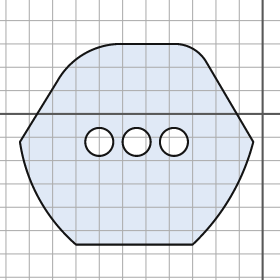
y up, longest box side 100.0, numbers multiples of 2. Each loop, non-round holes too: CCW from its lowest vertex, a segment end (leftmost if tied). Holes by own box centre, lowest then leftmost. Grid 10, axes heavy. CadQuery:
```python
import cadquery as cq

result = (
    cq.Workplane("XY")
    .moveTo(-80.0, -56.0)
    .lineTo(-30.0, -56.0)
    .threePointArc((-14.0, -36.0), (-4.0, -12.0))
    .lineTo(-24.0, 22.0)
    .threePointArc((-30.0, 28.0), (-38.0, 30.0))
    .lineTo(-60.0, 30.0)
    .threePointArc((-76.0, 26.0), (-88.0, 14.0))
    .lineTo(-104.0, -12.0)
    .threePointArc((-96.0, -36.0), (-80.0, -56.0))
    .close()
    .moveTo(-70.0, -12.0)
    .circle(6.0)
    .moveTo(-54.0, -12.0)
    .circle(6.0)
    .moveTo(-38.0, -12.0)
    .circle(6.0)
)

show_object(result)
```